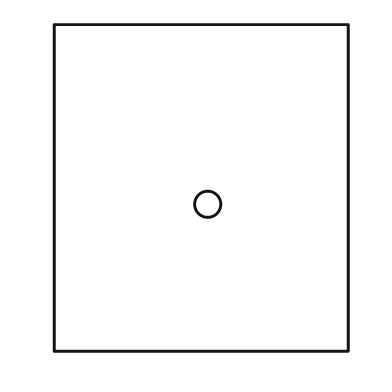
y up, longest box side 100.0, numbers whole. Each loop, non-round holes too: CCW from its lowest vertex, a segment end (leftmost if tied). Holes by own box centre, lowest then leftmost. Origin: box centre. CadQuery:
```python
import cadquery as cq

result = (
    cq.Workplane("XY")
    .moveTo(-45.0, -50.0)
    .lineTo(45.0, -50.0)
    .lineTo(45.0, 50.0)
    .lineTo(-45.0, 50.0)
    .close()
    .moveTo(2.0, -5.0)
    .circle(4.0)
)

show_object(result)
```